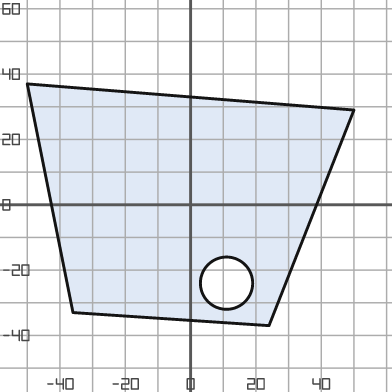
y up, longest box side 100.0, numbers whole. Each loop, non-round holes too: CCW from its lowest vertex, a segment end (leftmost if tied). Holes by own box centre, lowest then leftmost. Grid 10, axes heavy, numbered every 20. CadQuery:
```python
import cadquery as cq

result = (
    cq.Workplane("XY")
    .moveTo(24.0, -37.0)
    .lineTo(50.0, 29.0)
    .lineTo(-50.0, 37.0)
    .lineTo(-36.0, -33.0)
    .close()
    .moveTo(11.0, -24.0)
    .circle(8.0)
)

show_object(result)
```